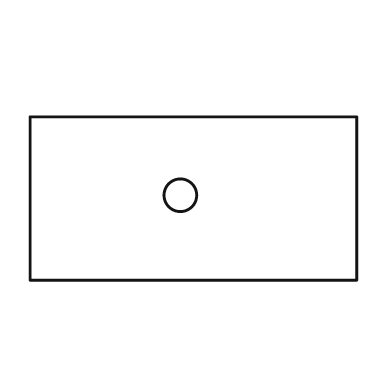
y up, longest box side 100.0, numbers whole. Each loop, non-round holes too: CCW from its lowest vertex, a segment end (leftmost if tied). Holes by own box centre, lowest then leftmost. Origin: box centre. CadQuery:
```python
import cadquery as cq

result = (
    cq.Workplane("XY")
    .moveTo(-50.0, -25.0)
    .lineTo(50.0, -25.0)
    .lineTo(50.0, 25.0)
    .lineTo(-50.0, 25.0)
    .close()
    .moveTo(-4.0, 1.0)
    .circle(5.0)
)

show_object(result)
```